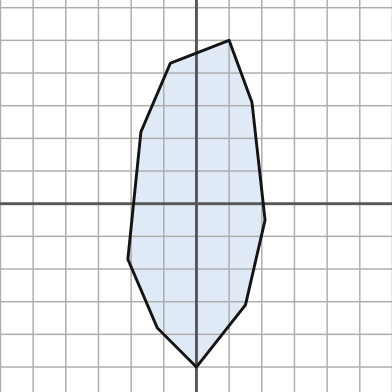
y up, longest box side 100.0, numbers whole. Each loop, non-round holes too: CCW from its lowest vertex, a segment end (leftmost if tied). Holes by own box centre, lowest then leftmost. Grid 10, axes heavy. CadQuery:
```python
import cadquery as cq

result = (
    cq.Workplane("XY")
    .moveTo(0.0, -50.0)
    .lineTo(15.0, -31.0)
    .lineTo(21.0, -5.0)
    .lineTo(17.0, 31.0)
    .lineTo(10.0, 50.0)
    .lineTo(-8.0, 43.0)
    .lineTo(-17.0, 22.0)
    .lineTo(-21.0, -17.0)
    .lineTo(-12.0, -38.0)
    .close()
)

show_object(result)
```